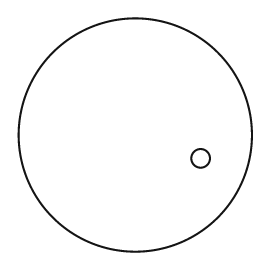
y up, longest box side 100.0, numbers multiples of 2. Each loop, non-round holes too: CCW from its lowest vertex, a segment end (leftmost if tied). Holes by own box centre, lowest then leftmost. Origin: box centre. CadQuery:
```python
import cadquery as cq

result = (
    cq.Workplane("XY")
    .moveTo(0.0, 0.0)
    .circle(50.0)
    .moveTo(28.0, -10.0)
    .circle(4.0)
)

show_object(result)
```